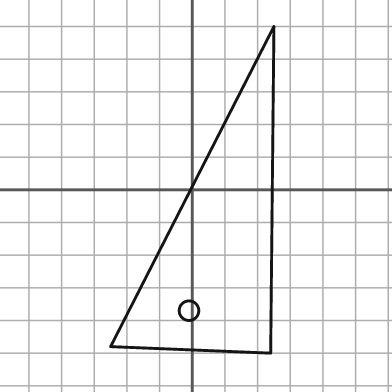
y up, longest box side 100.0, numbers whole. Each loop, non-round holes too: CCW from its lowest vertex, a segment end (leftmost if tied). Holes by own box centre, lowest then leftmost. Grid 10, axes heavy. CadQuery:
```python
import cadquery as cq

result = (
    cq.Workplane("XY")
    .moveTo(24.0, -50.0)
    .lineTo(25.0, 50.0)
    .lineTo(-25.0, -48.0)
    .close()
    .moveTo(-1.0, -37.0)
    .circle(3.0)
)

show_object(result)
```